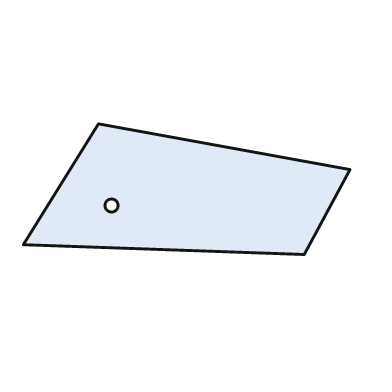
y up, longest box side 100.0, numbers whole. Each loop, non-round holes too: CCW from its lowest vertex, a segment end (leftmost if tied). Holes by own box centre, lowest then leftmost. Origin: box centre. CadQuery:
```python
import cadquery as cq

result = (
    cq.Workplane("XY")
    .moveTo(36.0, -20.0)
    .lineTo(50.0, 6.0)
    .lineTo(-27.0, 20.0)
    .lineTo(-50.0, -17.0)
    .close()
    .moveTo(-23.0, -5.0)
    .circle(2.0)
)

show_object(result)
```